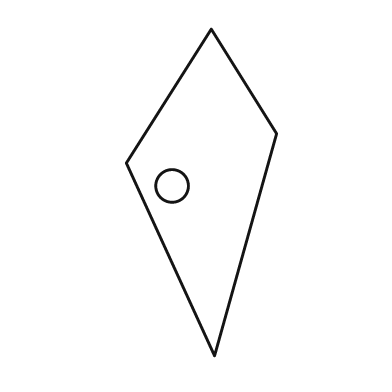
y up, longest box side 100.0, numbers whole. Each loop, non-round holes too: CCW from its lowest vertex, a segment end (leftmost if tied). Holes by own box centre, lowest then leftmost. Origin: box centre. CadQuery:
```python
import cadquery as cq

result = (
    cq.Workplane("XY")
    .moveTo(4.0, -50.0)
    .lineTo(23.0, 18.0)
    .lineTo(3.0, 50.0)
    .lineTo(-23.0, 9.0)
    .close()
    .moveTo(-9.0, 2.0)
    .circle(5.0)
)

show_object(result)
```